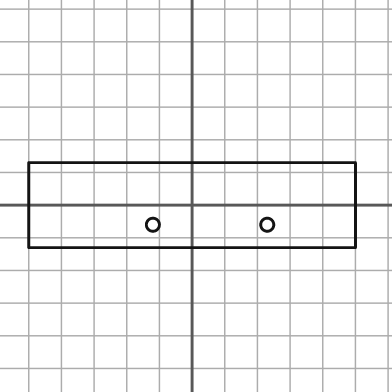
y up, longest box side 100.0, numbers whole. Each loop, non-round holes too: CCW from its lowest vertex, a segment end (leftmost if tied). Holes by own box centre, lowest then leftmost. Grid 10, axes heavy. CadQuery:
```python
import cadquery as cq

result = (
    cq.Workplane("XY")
    .moveTo(-50.0, -13.0)
    .lineTo(50.0, -13.0)
    .lineTo(50.0, 13.0)
    .lineTo(-50.0, 13.0)
    .close()
    .moveTo(-12.0, -6.0)
    .circle(2.0)
    .moveTo(23.0, -6.0)
    .circle(2.0)
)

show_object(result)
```